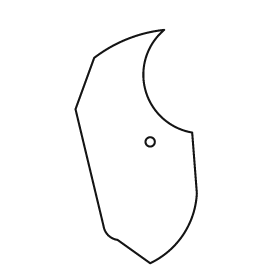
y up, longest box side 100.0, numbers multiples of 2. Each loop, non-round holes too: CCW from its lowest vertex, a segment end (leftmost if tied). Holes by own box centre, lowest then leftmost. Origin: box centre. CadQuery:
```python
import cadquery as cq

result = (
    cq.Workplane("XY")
    .moveTo(6.0, -50.0)
    .threePointArc((20.0, -38.0), (26.0, -20.0))
    .lineTo(24.0, 6.0)
    .threePointArc((4.0, 24.0), (12.0, 50.0))
    .threePointArc((-4.0, 46.0), (-18.0, 38.0))
    .lineTo(-26.0, 16.0)
    .lineTo(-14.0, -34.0)
    .threePointArc((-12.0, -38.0), (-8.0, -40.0))
    .close()
    .moveTo(6.0, 2.0)
    .circle(2.0)
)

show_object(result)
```